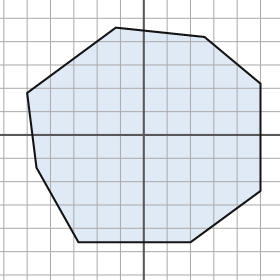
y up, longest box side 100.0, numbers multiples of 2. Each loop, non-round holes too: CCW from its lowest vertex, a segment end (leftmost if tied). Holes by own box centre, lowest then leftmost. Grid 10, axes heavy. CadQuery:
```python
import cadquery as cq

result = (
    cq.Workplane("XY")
    .moveTo(-28.0, -46.0)
    .lineTo(20.0, -46.0)
    .lineTo(50.0, -24.0)
    .lineTo(50.0, 22.0)
    .lineTo(26.0, 42.0)
    .lineTo(-12.0, 46.0)
    .lineTo(-50.0, 18.0)
    .lineTo(-46.0, -14.0)
    .close()
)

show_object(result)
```